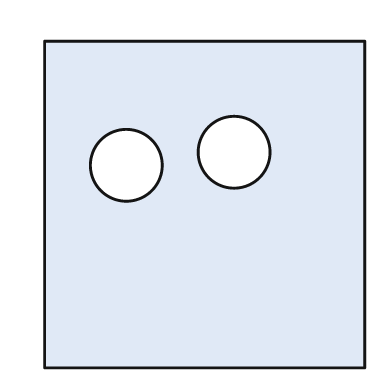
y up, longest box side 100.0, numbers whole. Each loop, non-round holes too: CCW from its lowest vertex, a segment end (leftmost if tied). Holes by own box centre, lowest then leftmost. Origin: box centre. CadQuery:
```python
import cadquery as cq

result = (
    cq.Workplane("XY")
    .moveTo(-49.0, -50.0)
    .lineTo(49.0, -50.0)
    .lineTo(49.0, 50.0)
    .lineTo(-49.0, 50.0)
    .close()
    .moveTo(-24.0, 12.0)
    .circle(11.0)
    .moveTo(9.0, 16.0)
    .circle(11.0)
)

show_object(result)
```